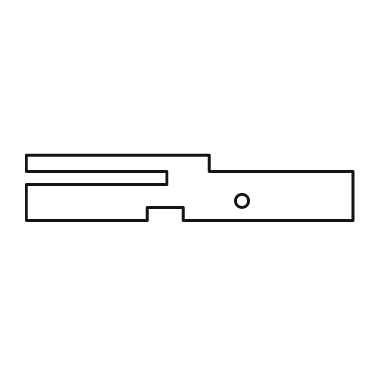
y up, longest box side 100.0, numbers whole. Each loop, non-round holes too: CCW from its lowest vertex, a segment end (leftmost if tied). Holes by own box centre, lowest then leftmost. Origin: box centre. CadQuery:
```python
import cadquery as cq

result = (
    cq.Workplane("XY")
    .moveTo(-50.0, -10.0)
    .lineTo(-13.0, -10.0)
    .lineTo(-13.0, -6.0)
    .lineTo(-2.0, -6.0)
    .lineTo(-2.0, -10.0)
    .lineTo(50.0, -10.0)
    .lineTo(50.0, 5.0)
    .lineTo(6.0, 5.0)
    .lineTo(6.0, 10.0)
    .lineTo(-50.0, 10.0)
    .lineTo(-50.0, 5.0)
    .lineTo(-7.0, 5.0)
    .lineTo(-7.0, 1.0)
    .lineTo(-50.0, 1.0)
    .close()
    .moveTo(16.0, -4.0)
    .circle(2.0)
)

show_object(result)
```